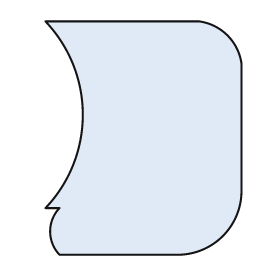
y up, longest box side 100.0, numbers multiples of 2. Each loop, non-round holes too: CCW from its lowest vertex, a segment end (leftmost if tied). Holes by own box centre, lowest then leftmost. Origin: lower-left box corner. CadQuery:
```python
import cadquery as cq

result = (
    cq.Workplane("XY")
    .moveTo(6.0, 0.0)
    .lineTo(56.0, 0.0)
    .threePointArc((76.0, 8.0), (84.0, 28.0))
    .lineTo(84.0, 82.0)
    .threePointArc((78.0, 94.0), (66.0, 100.0))
    .lineTo(0.0, 100.0)
    .threePointArc((16.0, 60.0), (0.0, 20.0))
    .lineTo(6.0, 20.0)
    .threePointArc((2.0, 10.0), (6.0, 0.0))
    .close()
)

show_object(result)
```